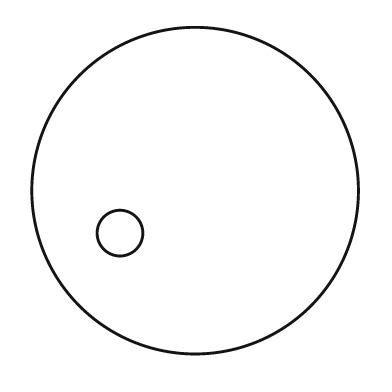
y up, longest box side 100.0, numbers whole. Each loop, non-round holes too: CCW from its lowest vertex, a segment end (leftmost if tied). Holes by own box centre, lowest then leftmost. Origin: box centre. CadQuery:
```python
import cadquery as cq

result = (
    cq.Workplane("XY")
    .moveTo(0.0, 0.0)
    .circle(50.0)
    .moveTo(-23.0, -13.0)
    .circle(7.0)
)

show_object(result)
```